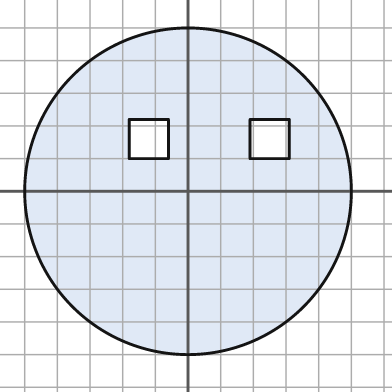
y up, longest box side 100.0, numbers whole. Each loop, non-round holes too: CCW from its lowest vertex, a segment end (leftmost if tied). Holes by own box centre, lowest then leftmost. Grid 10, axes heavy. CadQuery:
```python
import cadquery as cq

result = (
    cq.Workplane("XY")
    .moveTo(0.0, 0.0)
    .circle(50.0)
    .moveTo(-18.0, 10.0)
    .lineTo(-6.0, 10.0)
    .lineTo(-6.0, 22.0)
    .lineTo(-18.0, 22.0)
    .close()
    .moveTo(19.0, 10.0)
    .lineTo(31.0, 10.0)
    .lineTo(31.0, 22.0)
    .lineTo(19.0, 22.0)
    .close()
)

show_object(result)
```